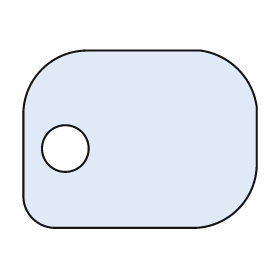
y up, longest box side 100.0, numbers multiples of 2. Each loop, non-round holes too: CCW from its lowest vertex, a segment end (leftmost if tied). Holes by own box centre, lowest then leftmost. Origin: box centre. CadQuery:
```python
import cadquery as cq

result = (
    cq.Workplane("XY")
    .moveTo(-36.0, -38.0)
    .lineTo(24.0, -38.0)
    .threePointArc((42.0, -30.0), (50.0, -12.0))
    .lineTo(50.0, 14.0)
    .threePointArc((42.0, 30.0), (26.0, 38.0))
    .lineTo(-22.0, 38.0)
    .threePointArc((-42.0, 30.0), (-50.0, 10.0))
    .lineTo(-50.0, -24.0)
    .threePointArc((-46.0, -34.0), (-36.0, -38.0))
    .close()
    .moveTo(-32.0, -4.0)
    .circle(10.0)
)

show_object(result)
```